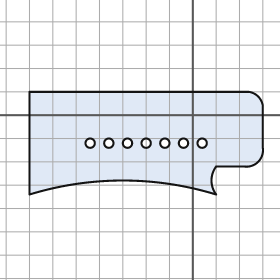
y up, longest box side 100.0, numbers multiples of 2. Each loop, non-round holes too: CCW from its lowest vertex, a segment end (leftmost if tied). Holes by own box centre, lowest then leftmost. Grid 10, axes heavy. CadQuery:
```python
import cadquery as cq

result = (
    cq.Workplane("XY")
    .moveTo(-70.0, -34.0)
    .threePointArc((-30.0, -28.0), (10.0, -34.0))
    .threePointArc((8.0, -28.0), (10.0, -22.0))
    .lineTo(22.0, -22.0)
    .threePointArc((28.0, -20.0), (30.0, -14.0))
    .lineTo(30.0, 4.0)
    .threePointArc((28.0, 8.0), (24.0, 10.0))
    .lineTo(-70.0, 10.0)
    .close()
    .moveTo(-44.0, -12.0)
    .circle(2.0)
    .moveTo(-36.0, -12.0)
    .circle(2.0)
    .moveTo(-28.0, -12.0)
    .circle(2.0)
    .moveTo(-20.0, -12.0)
    .circle(2.0)
    .moveTo(-12.0, -12.0)
    .circle(2.0)
    .moveTo(-4.0, -12.0)
    .circle(2.0)
    .moveTo(4.0, -12.0)
    .circle(2.0)
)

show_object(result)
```